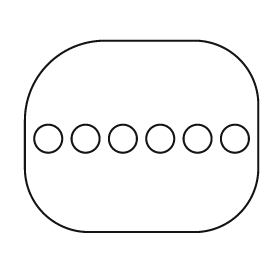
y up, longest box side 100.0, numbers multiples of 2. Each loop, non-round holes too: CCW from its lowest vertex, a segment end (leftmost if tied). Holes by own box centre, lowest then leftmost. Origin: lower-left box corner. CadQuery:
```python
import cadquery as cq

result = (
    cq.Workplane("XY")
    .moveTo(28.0, 0.0)
    .lineTo(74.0, 0.0)
    .threePointArc((92.0, 8.0), (100.0, 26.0))
    .lineTo(100.0, 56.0)
    .threePointArc((92.0, 74.0), (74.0, 82.0))
    .lineTo(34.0, 82.0)
    .threePointArc((10.0, 72.0), (0.0, 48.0))
    .lineTo(0.0, 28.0)
    .threePointArc((8.0, 8.0), (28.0, 0.0))
    .close()
    .moveTo(10.0, 40.0)
    .circle(6.0)
    .moveTo(26.0, 40.0)
    .circle(6.0)
    .moveTo(42.0, 40.0)
    .circle(6.0)
    .moveTo(58.0, 40.0)
    .circle(6.0)
    .moveTo(74.0, 40.0)
    .circle(6.0)
    .moveTo(90.0, 40.0)
    .circle(6.0)
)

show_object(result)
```